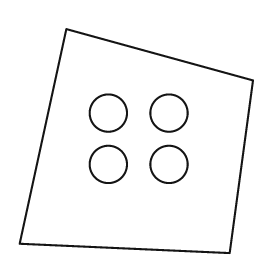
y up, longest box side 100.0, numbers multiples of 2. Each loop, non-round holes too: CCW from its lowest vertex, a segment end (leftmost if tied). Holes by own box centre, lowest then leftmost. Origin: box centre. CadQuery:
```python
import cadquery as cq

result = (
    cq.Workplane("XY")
    .moveTo(40.0, -48.0)
    .lineTo(50.0, 26.0)
    .lineTo(-30.0, 48.0)
    .lineTo(-50.0, -44.0)
    .close()
    .moveTo(-12.0, -10.0)
    .circle(8.0)
    .moveTo(14.0, -10.0)
    .circle(8.0)
    .moveTo(-12.0, 12.0)
    .circle(8.0)
    .moveTo(14.0, 12.0)
    .circle(8.0)
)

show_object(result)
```